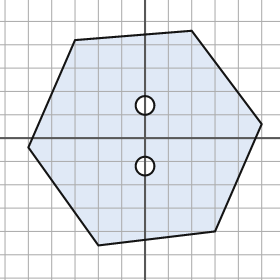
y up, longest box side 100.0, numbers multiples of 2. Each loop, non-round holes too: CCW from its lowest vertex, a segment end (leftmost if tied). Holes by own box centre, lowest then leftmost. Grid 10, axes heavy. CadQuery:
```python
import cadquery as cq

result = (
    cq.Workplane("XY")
    .moveTo(-20.0, -46.0)
    .lineTo(30.0, -40.0)
    .lineTo(50.0, 6.0)
    .lineTo(20.0, 46.0)
    .lineTo(-30.0, 42.0)
    .lineTo(-50.0, -4.0)
    .close()
    .moveTo(0.0, -12.0)
    .circle(4.0)
    .moveTo(0.0, 14.0)
    .circle(4.0)
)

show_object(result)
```